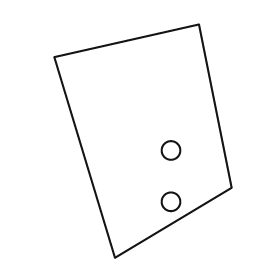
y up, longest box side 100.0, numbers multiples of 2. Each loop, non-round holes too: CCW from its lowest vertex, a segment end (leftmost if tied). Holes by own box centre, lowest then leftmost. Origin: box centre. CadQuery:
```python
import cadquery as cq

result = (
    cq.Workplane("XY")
    .moveTo(-12.0, -50.0)
    .lineTo(38.0, -20.0)
    .lineTo(24.0, 50.0)
    .lineTo(-38.0, 36.0)
    .close()
    .moveTo(12.0, -26.0)
    .circle(4.0)
    .moveTo(12.0, -4.0)
    .circle(4.0)
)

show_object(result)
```